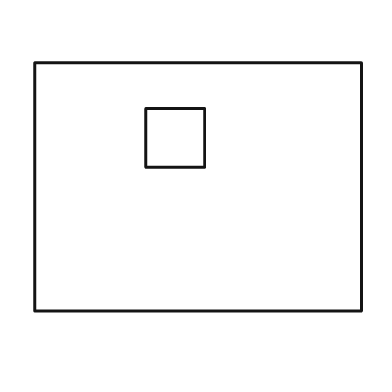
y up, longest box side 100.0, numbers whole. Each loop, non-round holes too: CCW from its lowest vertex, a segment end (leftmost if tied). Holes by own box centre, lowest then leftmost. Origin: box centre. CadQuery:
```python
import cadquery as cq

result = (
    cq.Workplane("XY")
    .moveTo(-50.0, -38.0)
    .lineTo(50.0, -38.0)
    .lineTo(50.0, 38.0)
    .lineTo(-50.0, 38.0)
    .close()
    .moveTo(-16.0, 6.0)
    .lineTo(2.0, 6.0)
    .lineTo(2.0, 24.0)
    .lineTo(-16.0, 24.0)
    .close()
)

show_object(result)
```